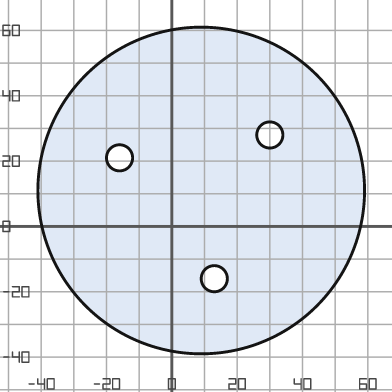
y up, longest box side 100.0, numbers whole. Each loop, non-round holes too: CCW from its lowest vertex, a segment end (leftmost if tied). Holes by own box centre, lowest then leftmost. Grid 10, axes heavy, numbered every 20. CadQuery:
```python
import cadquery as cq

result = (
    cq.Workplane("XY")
    .moveTo(9.0, 11.0)
    .circle(50.0)
    .moveTo(13.0, -16.0)
    .circle(4.0)
    .moveTo(-16.0, 21.0)
    .circle(4.0)
    .moveTo(30.0, 28.0)
    .circle(4.0)
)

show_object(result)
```